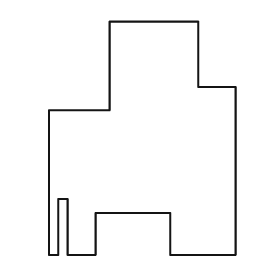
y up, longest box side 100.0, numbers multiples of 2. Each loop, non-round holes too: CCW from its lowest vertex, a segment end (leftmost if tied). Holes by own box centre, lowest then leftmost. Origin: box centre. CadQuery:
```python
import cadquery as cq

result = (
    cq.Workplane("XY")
    .moveTo(-40.0, -50.0)
    .lineTo(-36.0, -50.0)
    .lineTo(-36.0, -26.0)
    .lineTo(-32.0, -26.0)
    .lineTo(-32.0, -50.0)
    .lineTo(-20.0, -50.0)
    .lineTo(-20.0, -32.0)
    .lineTo(12.0, -32.0)
    .lineTo(12.0, -50.0)
    .lineTo(40.0, -50.0)
    .lineTo(40.0, 22.0)
    .lineTo(24.0, 22.0)
    .lineTo(24.0, 50.0)
    .lineTo(-14.0, 50.0)
    .lineTo(-14.0, 12.0)
    .lineTo(-40.0, 12.0)
    .close()
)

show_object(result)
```